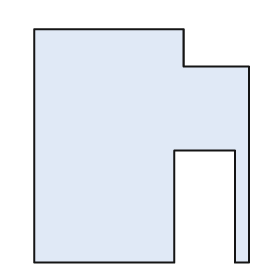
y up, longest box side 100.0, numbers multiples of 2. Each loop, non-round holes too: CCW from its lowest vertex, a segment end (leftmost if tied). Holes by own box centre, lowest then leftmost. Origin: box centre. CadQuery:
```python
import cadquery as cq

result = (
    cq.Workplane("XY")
    .moveTo(-46.0, -50.0)
    .lineTo(14.0, -50.0)
    .lineTo(14.0, -2.0)
    .lineTo(40.0, -2.0)
    .lineTo(40.0, -50.0)
    .lineTo(46.0, -50.0)
    .lineTo(46.0, 34.0)
    .lineTo(18.0, 34.0)
    .lineTo(18.0, 50.0)
    .lineTo(-46.0, 50.0)
    .close()
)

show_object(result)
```